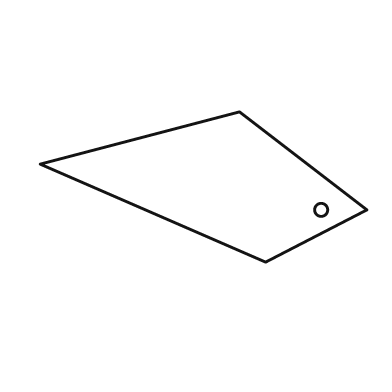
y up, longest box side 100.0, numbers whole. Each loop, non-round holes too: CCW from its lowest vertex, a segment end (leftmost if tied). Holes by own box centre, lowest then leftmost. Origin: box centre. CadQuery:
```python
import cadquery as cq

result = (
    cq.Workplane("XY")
    .moveTo(19.0, -23.0)
    .lineTo(50.0, -7.0)
    .lineTo(11.0, 23.0)
    .lineTo(-50.0, 7.0)
    .close()
    .moveTo(36.0, -7.0)
    .circle(2.0)
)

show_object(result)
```